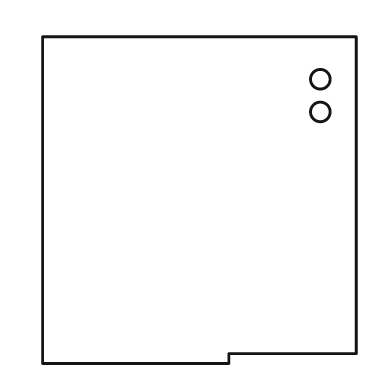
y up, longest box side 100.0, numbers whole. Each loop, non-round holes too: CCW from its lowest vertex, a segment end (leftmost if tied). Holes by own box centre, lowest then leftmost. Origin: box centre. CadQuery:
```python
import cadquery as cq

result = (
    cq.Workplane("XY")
    .moveTo(-48.0, -50.0)
    .lineTo(9.0, -50.0)
    .lineTo(9.0, -47.0)
    .lineTo(48.0, -47.0)
    .lineTo(48.0, 50.0)
    .lineTo(-48.0, 50.0)
    .close()
    .moveTo(37.0, 27.0)
    .circle(3.0)
    .moveTo(37.0, 37.0)
    .circle(3.0)
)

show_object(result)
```